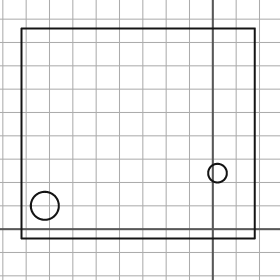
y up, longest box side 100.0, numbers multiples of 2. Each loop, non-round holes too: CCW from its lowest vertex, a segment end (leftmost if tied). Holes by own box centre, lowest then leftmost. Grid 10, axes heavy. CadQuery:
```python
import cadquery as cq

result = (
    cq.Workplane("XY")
    .moveTo(-82.0, -4.0)
    .lineTo(18.0, -4.0)
    .lineTo(18.0, 86.0)
    .lineTo(-82.0, 86.0)
    .close()
    .moveTo(-72.0, 10.0)
    .circle(6.0)
    .moveTo(2.0, 24.0)
    .circle(4.0)
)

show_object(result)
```